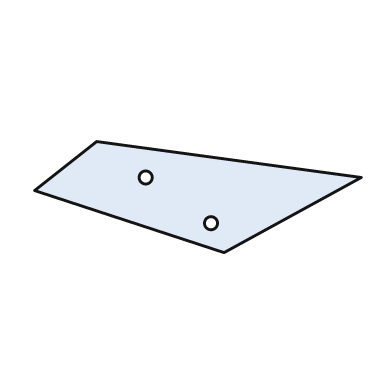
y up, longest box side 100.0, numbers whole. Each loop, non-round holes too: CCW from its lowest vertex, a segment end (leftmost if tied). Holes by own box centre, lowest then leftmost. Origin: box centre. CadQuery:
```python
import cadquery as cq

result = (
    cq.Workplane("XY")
    .moveTo(8.0, -17.0)
    .lineTo(50.0, 6.0)
    .lineTo(-31.0, 17.0)
    .lineTo(-50.0, 2.0)
    .close()
    .moveTo(4.0, -8.0)
    .circle(2.0)
    .moveTo(-16.0, 6.0)
    .circle(2.0)
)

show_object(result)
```